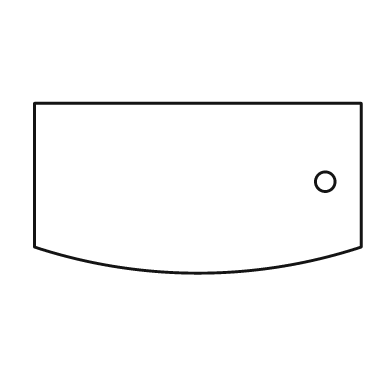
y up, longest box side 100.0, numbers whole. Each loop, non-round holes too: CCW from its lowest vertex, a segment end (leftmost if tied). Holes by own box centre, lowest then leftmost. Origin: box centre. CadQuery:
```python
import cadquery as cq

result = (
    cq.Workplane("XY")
    .moveTo(-50.0, -18.0)
    .threePointArc((0.0, -26.0), (50.0, -18.0))
    .lineTo(50.0, 26.0)
    .lineTo(-50.0, 26.0)
    .close()
    .moveTo(39.0, 2.0)
    .circle(3.0)
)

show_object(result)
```